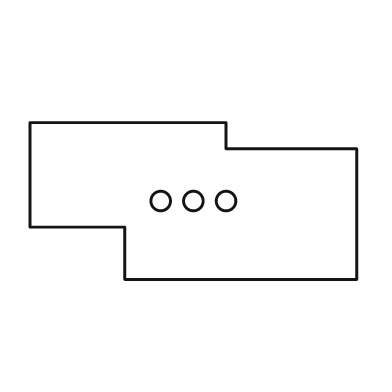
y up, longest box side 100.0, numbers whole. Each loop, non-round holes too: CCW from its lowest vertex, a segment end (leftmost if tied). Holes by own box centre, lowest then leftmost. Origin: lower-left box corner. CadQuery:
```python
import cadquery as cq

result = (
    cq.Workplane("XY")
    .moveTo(29.0, 0.0)
    .lineTo(100.0, 0.0)
    .lineTo(100.0, 40.0)
    .lineTo(60.0, 40.0)
    .lineTo(60.0, 48.0)
    .lineTo(0.0, 48.0)
    .lineTo(0.0, 16.0)
    .lineTo(29.0, 16.0)
    .close()
    .moveTo(40.0, 24.0)
    .circle(3.0)
    .moveTo(50.0, 24.0)
    .circle(3.0)
    .moveTo(60.0, 24.0)
    .circle(3.0)
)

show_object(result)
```